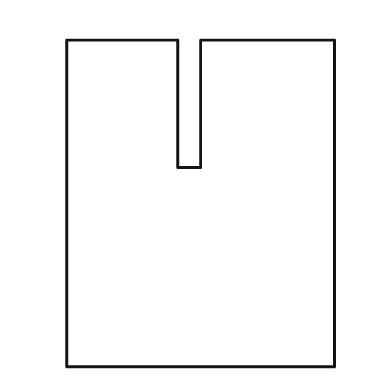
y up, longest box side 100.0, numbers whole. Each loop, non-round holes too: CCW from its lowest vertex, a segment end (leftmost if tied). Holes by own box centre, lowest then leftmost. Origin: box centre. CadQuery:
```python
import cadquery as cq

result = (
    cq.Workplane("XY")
    .moveTo(-41.0, -50.0)
    .lineTo(41.0, -50.0)
    .lineTo(41.0, 50.0)
    .lineTo(0.0, 50.0)
    .lineTo(0.0, 11.0)
    .lineTo(-7.0, 11.0)
    .lineTo(-7.0, 50.0)
    .lineTo(-41.0, 50.0)
    .close()
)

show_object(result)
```